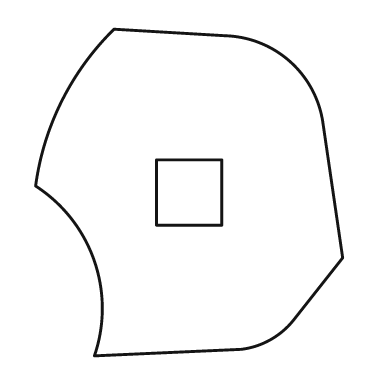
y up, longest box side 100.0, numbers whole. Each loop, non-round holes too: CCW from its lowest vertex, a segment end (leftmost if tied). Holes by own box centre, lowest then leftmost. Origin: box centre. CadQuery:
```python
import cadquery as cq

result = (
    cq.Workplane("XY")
    .moveTo(-29.0, -50.0)
    .lineTo(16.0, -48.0)
    .threePointArc((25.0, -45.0), (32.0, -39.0))
    .lineTo(47.0, -20.0)
    .lineTo(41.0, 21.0)
    .threePointArc((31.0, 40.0), (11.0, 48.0))
    .lineTo(-23.0, 50.0)
    .threePointArc((-39.0, 28.0), (-47.0, 2.0))
    .threePointArc((-29.0, -21.0), (-29.0, -50.0))
    .close()
    .moveTo(-10.0, -10.0)
    .lineTo(10.0, -10.0)
    .lineTo(10.0, 10.0)
    .lineTo(-10.0, 10.0)
    .close()
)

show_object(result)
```